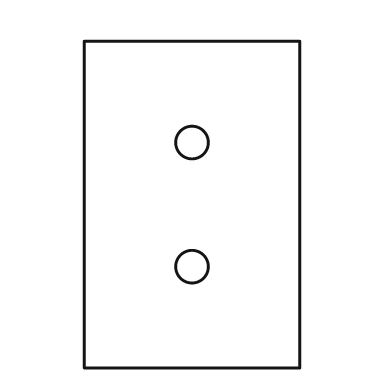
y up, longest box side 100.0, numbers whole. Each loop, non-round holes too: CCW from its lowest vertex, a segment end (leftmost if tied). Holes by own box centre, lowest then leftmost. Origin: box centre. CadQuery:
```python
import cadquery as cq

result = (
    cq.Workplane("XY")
    .moveTo(-33.0, -50.0)
    .lineTo(33.0, -50.0)
    .lineTo(33.0, 50.0)
    .lineTo(-33.0, 50.0)
    .close()
    .moveTo(0.0, -19.0)
    .circle(5.0)
    .moveTo(0.0, 19.0)
    .circle(5.0)
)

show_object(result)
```